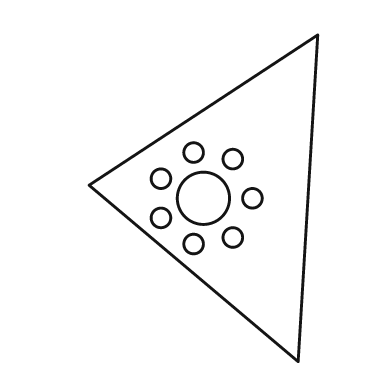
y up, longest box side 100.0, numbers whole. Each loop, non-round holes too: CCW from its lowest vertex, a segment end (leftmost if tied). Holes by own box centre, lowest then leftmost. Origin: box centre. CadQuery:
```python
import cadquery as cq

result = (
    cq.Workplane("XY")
    .moveTo(29.0, -50.0)
    .lineTo(35.0, 50.0)
    .lineTo(-35.0, 4.0)
    .close()
    .moveTo(-3.0, -14.0)
    .circle(3.0)
    .moveTo(9.0, -12.0)
    .circle(3.0)
    .moveTo(-13.0, -6.0)
    .circle(3.0)
    .moveTo(0.0, 0.0)
    .circle(8.0)
    .moveTo(15.0, 0.0)
    .circle(3.0)
    .moveTo(-13.0, 6.0)
    .circle(3.0)
    .moveTo(9.0, 12.0)
    .circle(3.0)
    .moveTo(-3.0, 14.0)
    .circle(3.0)
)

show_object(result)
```